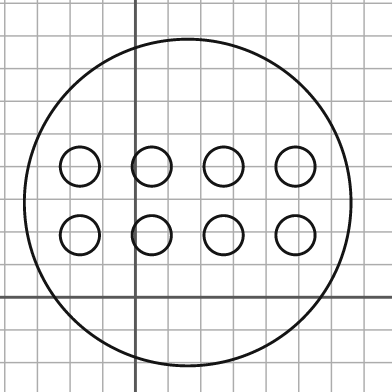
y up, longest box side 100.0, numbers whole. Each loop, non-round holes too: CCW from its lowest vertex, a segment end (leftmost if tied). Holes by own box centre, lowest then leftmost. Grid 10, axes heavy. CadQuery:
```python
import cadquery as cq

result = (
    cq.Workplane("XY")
    .moveTo(16.0, 29.0)
    .circle(50.0)
    .moveTo(-17.0, 19.0)
    .circle(6.0)
    .moveTo(5.0, 19.0)
    .circle(6.0)
    .moveTo(27.0, 19.0)
    .circle(6.0)
    .moveTo(49.0, 19.0)
    .circle(6.0)
    .moveTo(-17.0, 40.0)
    .circle(6.0)
    .moveTo(5.0, 40.0)
    .circle(6.0)
    .moveTo(27.0, 40.0)
    .circle(6.0)
    .moveTo(49.0, 40.0)
    .circle(6.0)
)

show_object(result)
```